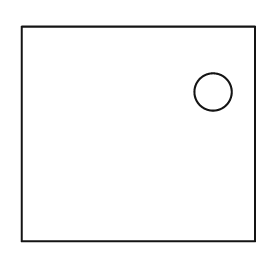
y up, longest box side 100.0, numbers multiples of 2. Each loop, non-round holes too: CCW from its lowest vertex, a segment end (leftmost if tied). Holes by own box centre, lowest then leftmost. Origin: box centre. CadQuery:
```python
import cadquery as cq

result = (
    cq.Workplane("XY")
    .moveTo(-50.0, -46.0)
    .lineTo(50.0, -46.0)
    .lineTo(50.0, 46.0)
    .lineTo(-50.0, 46.0)
    .close()
    .moveTo(32.0, 18.0)
    .circle(8.0)
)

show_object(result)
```